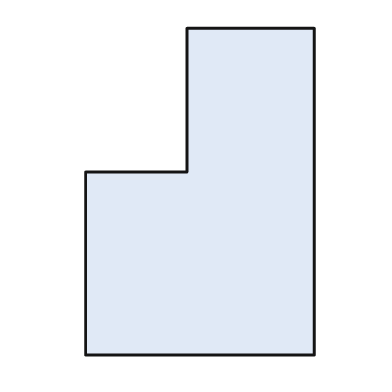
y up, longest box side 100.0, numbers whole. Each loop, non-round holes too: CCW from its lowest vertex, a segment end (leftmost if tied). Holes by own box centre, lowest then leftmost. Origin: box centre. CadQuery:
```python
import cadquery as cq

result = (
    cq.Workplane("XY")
    .moveTo(-35.0, -50.0)
    .lineTo(35.0, -50.0)
    .lineTo(35.0, 50.0)
    .lineTo(-4.0, 50.0)
    .lineTo(-4.0, 6.0)
    .lineTo(-35.0, 6.0)
    .close()
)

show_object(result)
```